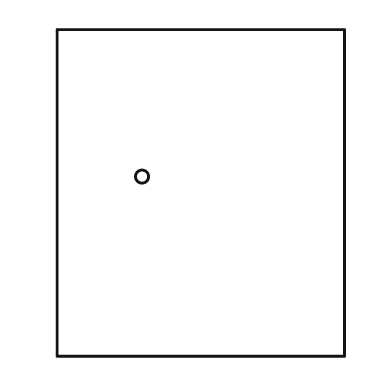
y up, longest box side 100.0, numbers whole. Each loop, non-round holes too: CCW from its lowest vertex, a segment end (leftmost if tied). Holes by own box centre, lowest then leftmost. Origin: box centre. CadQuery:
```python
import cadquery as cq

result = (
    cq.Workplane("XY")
    .moveTo(-44.0, -50.0)
    .lineTo(44.0, -50.0)
    .lineTo(44.0, 50.0)
    .lineTo(-44.0, 50.0)
    .close()
    .moveTo(-18.0, 5.0)
    .circle(2.0)
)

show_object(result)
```